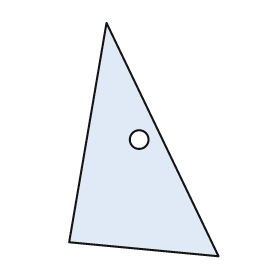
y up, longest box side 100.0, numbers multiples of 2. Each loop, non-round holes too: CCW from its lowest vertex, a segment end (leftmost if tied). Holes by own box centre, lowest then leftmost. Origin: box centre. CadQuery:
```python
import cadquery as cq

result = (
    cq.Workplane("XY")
    .moveTo(32.0, -50.0)
    .lineTo(-16.0, 50.0)
    .lineTo(-32.0, -44.0)
    .close()
    .moveTo(-2.0, 0.0)
    .circle(4.0)
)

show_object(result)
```